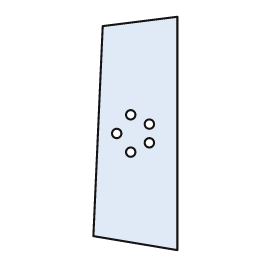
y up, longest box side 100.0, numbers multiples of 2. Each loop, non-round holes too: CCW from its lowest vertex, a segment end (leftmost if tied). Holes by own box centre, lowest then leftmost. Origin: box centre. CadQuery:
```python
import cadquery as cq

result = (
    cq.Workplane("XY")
    .moveTo(18.0, -50.0)
    .lineTo(18.0, 50.0)
    .lineTo(-14.0, 46.0)
    .lineTo(-18.0, -44.0)
    .close()
    .moveTo(-2.0, -8.0)
    .circle(2.0)
    .moveTo(6.0, -4.0)
    .circle(2.0)
    .moveTo(-8.0, 0.0)
    .circle(2.0)
    .moveTo(6.0, 4.0)
    .circle(2.0)
    .moveTo(-2.0, 8.0)
    .circle(2.0)
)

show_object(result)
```